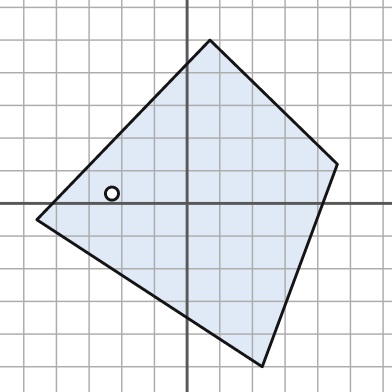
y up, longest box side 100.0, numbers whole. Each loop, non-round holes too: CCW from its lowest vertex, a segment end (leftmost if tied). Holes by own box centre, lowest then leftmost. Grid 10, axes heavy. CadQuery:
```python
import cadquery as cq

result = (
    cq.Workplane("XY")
    .moveTo(23.0, -50.0)
    .lineTo(46.0, 12.0)
    .lineTo(7.0, 50.0)
    .lineTo(-46.0, -5.0)
    .close()
    .moveTo(-23.0, 3.0)
    .circle(2.0)
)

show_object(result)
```